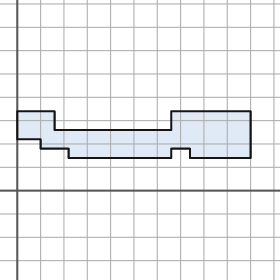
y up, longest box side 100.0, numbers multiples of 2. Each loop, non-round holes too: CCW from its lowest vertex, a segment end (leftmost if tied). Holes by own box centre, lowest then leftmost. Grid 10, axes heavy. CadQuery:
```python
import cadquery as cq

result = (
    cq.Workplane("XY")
    .moveTo(22.0, 14.0)
    .lineTo(66.0, 14.0)
    .lineTo(66.0, 18.0)
    .lineTo(74.0, 18.0)
    .lineTo(74.0, 14.0)
    .lineTo(100.0, 14.0)
    .lineTo(100.0, 34.0)
    .lineTo(66.0, 34.0)
    .lineTo(66.0, 26.0)
    .lineTo(16.0, 26.0)
    .lineTo(16.0, 34.0)
    .lineTo(0.0, 34.0)
    .lineTo(0.0, 22.0)
    .lineTo(10.0, 22.0)
    .lineTo(10.0, 18.0)
    .lineTo(22.0, 18.0)
    .close()
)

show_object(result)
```